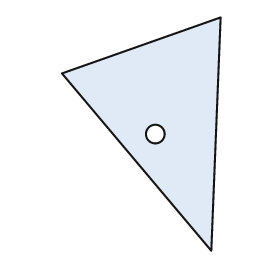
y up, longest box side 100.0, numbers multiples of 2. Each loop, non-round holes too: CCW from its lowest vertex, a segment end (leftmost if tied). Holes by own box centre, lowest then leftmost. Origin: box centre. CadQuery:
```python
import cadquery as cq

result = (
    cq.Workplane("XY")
    .moveTo(30.0, -50.0)
    .lineTo(34.0, 50.0)
    .lineTo(-34.0, 26.0)
    .close()
    .moveTo(6.0, 0.0)
    .circle(4.0)
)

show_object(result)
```